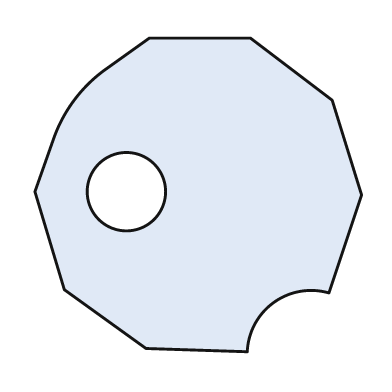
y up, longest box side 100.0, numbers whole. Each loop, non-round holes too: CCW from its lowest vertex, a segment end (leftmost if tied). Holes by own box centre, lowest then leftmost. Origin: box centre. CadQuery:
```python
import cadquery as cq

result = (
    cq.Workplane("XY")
    .moveTo(15.0, -48.0)
    .threePointArc((23.0, -33.0), (40.0, -30.0))
    .lineTo(50.0, 0.0)
    .lineTo(41.0, 29.0)
    .lineTo(16.0, 48.0)
    .lineTo(-15.0, 48.0)
    .lineTo(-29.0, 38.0)
    .threePointArc((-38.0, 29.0), (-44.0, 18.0))
    .lineTo(-50.0, 1.0)
    .lineTo(-41.0, -29.0)
    .lineTo(-16.0, -47.0)
    .close()
    .moveTo(-22.0, 1.0)
    .circle(12.0)
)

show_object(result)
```